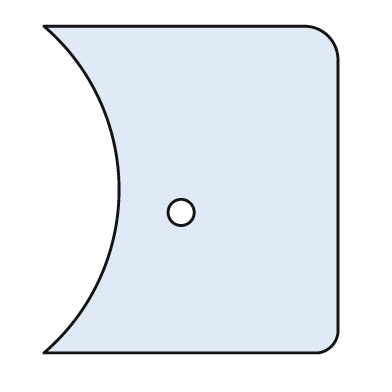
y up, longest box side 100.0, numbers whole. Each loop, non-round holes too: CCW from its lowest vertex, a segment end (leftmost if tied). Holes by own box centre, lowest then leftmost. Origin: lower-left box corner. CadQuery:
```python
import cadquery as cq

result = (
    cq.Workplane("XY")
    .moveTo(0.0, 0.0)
    .lineTo(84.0, 0.0)
    .threePointArc((88.0, 2.0), (90.0, 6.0))
    .lineTo(90.0, 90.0)
    .threePointArc((87.0, 97.0), (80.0, 100.0))
    .lineTo(0.0, 100.0)
    .threePointArc((23.0, 50.0), (0.0, 0.0))
    .close()
    .moveTo(42.0, 43.0)
    .circle(4.0)
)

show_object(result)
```